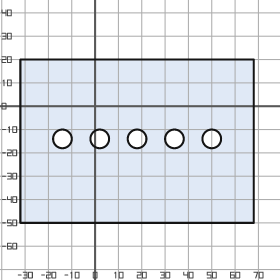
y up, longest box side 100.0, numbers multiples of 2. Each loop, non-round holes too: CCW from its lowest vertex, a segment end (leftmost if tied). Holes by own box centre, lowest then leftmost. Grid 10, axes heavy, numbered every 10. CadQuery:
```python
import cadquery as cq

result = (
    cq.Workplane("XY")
    .moveTo(-32.0, -50.0)
    .lineTo(68.0, -50.0)
    .lineTo(68.0, 20.0)
    .lineTo(-32.0, 20.0)
    .close()
    .moveTo(-14.0, -14.0)
    .circle(4.0)
    .moveTo(2.0, -14.0)
    .circle(4.0)
    .moveTo(18.0, -14.0)
    .circle(4.0)
    .moveTo(34.0, -14.0)
    .circle(4.0)
    .moveTo(50.0, -14.0)
    .circle(4.0)
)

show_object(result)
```